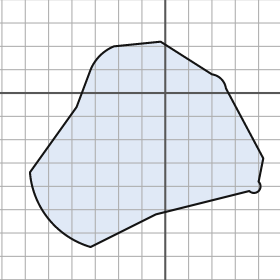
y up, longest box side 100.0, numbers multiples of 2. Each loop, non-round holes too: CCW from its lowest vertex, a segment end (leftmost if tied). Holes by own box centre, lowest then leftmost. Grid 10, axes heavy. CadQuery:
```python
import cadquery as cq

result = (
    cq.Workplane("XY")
    .moveTo(-32.0, -66.0)
    .lineTo(-4.0, -52.0)
    .lineTo(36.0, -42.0)
    .threePointArc((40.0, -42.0), (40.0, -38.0))
    .lineTo(42.0, -28.0)
    .lineTo(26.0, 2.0)
    .threePointArc((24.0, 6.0), (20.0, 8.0))
    .lineTo(-2.0, 22.0)
    .lineTo(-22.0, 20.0)
    .threePointArc((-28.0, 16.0), (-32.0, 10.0))
    .lineTo(-38.0, -6.0)
    .lineTo(-58.0, -34.0)
    .threePointArc((-50.0, -54.0), (-32.0, -66.0))
    .close()
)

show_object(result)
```